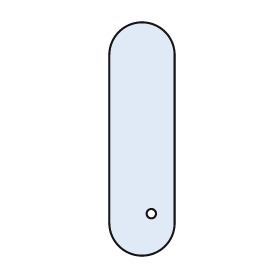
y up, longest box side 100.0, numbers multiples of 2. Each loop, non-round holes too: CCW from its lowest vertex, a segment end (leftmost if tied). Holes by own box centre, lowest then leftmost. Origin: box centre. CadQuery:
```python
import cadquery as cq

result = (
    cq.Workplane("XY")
    .moveTo(-14.0, -36.0)
    .threePointArc((0.0, -50.0), (14.0, -36.0))
    .lineTo(14.0, 36.0)
    .threePointArc((0.0, 50.0), (-14.0, 36.0))
    .close()
    .moveTo(4.0, -32.0)
    .circle(2.0)
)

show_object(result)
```